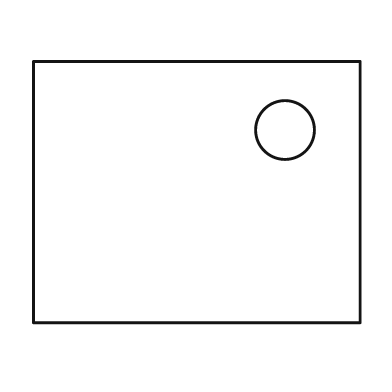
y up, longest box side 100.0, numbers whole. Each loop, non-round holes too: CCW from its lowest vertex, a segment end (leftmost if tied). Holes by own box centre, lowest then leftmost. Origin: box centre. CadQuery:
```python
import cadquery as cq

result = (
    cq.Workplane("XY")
    .moveTo(-50.0, -40.0)
    .lineTo(50.0, -40.0)
    .lineTo(50.0, 40.0)
    .lineTo(-50.0, 40.0)
    .close()
    .moveTo(27.0, 19.0)
    .circle(9.0)
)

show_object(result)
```